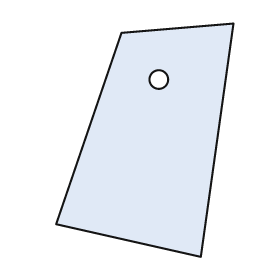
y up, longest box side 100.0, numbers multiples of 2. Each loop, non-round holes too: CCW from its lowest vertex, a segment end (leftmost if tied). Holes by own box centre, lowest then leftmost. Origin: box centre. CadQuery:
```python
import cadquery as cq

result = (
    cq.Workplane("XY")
    .moveTo(24.0, -50.0)
    .lineTo(38.0, 50.0)
    .lineTo(-10.0, 46.0)
    .lineTo(-38.0, -36.0)
    .close()
    .moveTo(6.0, 26.0)
    .circle(4.0)
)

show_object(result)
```